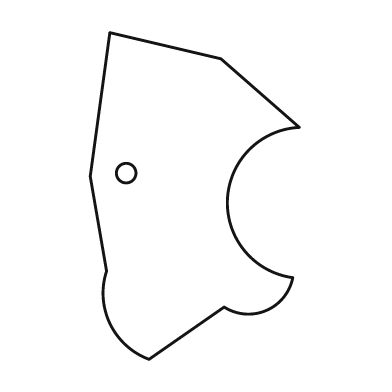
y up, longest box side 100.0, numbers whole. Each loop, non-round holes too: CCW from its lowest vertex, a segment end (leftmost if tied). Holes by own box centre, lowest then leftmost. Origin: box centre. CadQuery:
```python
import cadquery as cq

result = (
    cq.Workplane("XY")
    .moveTo(-14.0, -50.0)
    .lineTo(9.0, -34.0)
    .threePointArc((22.0, -35.0), (30.0, -25.0))
    .threePointArc((10.0, -1.0), (32.0, 21.0))
    .lineTo(8.0, 42.0)
    .lineTo(-26.0, 50.0)
    .lineTo(-32.0, 6.0)
    .lineTo(-27.0, -23.0)
    .threePointArc((-26.0, -39.0), (-14.0, -50.0))
    .close()
    .moveTo(-21.0, 7.0)
    .circle(3.0)
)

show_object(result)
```